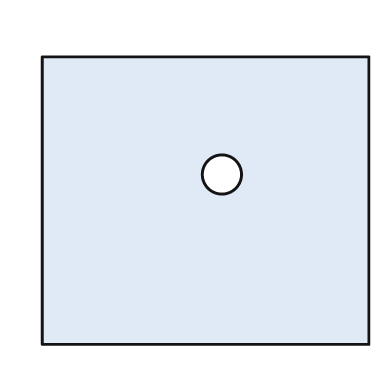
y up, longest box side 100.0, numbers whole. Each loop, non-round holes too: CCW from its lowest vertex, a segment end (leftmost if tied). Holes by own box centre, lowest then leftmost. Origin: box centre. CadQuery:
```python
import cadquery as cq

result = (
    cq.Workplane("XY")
    .moveTo(-50.0, -44.0)
    .lineTo(50.0, -44.0)
    .lineTo(50.0, 44.0)
    .lineTo(-50.0, 44.0)
    .close()
    .moveTo(5.0, 8.0)
    .circle(6.0)
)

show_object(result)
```